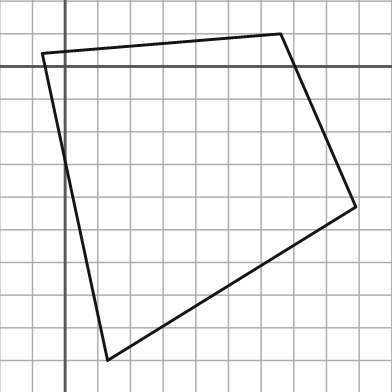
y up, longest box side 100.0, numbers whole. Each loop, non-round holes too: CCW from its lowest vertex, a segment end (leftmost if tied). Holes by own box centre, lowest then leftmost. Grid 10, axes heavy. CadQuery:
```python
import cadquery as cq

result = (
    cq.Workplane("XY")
    .moveTo(13.0, -90.0)
    .lineTo(89.0, -43.0)
    .lineTo(66.0, 10.0)
    .lineTo(-7.0, 4.0)
    .close()
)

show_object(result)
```